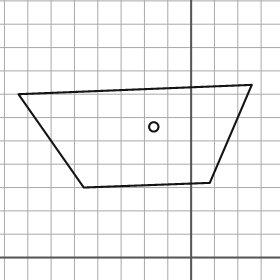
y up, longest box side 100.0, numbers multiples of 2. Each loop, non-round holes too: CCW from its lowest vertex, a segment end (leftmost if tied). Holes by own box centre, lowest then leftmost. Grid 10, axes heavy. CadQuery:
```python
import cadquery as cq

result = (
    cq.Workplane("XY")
    .moveTo(-46.0, 30.0)
    .lineTo(8.0, 32.0)
    .lineTo(26.0, 74.0)
    .lineTo(-74.0, 70.0)
    .close()
    .moveTo(-16.0, 56.0)
    .circle(2.0)
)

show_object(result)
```